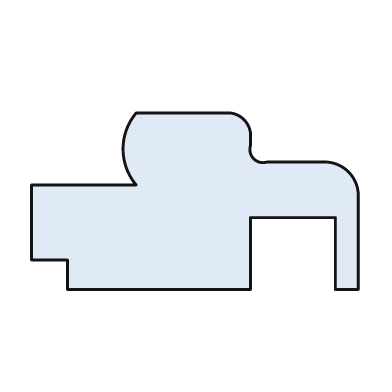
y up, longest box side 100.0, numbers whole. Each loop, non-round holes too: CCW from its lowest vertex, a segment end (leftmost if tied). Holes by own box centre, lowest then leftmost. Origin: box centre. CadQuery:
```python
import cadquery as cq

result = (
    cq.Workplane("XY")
    .moveTo(-39.0, -27.0)
    .lineTo(17.0, -27.0)
    .lineTo(17.0, -5.0)
    .lineTo(43.0, -5.0)
    .lineTo(43.0, -27.0)
    .lineTo(50.0, -27.0)
    .lineTo(50.0, 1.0)
    .threePointArc((47.0, 9.0), (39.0, 12.0))
    .lineTo(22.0, 12.0)
    .threePointArc((18.0, 13.0), (17.0, 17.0))
    .lineTo(17.0, 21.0)
    .threePointArc((15.0, 25.0), (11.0, 27.0))
    .lineTo(-18.0, 27.0)
    .threePointArc((-22.0, 16.0), (-18.0, 5.0))
    .lineTo(-50.0, 5.0)
    .lineTo(-50.0, -18.0)
    .lineTo(-39.0, -18.0)
    .close()
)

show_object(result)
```